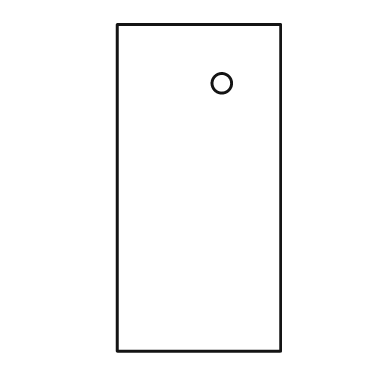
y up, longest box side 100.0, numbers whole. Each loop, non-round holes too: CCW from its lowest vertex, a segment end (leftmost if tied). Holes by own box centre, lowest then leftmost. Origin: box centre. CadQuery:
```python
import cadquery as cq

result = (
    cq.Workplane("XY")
    .moveTo(-25.0, -50.0)
    .lineTo(25.0, -50.0)
    .lineTo(25.0, 50.0)
    .lineTo(-25.0, 50.0)
    .close()
    .moveTo(7.0, 32.0)
    .circle(3.0)
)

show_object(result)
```